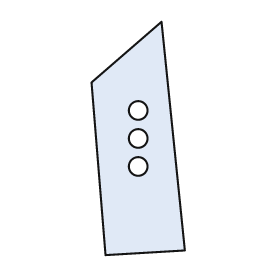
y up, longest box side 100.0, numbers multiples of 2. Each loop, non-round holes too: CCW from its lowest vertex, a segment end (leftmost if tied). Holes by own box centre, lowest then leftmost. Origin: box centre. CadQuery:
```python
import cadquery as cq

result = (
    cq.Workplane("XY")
    .moveTo(-14.0, -50.0)
    .lineTo(20.0, -48.0)
    .lineTo(10.0, 50.0)
    .lineTo(-20.0, 24.0)
    .close()
    .moveTo(0.0, -12.0)
    .circle(4.0)
    .moveTo(0.0, 0.0)
    .circle(4.0)
    .moveTo(0.0, 12.0)
    .circle(4.0)
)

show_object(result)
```